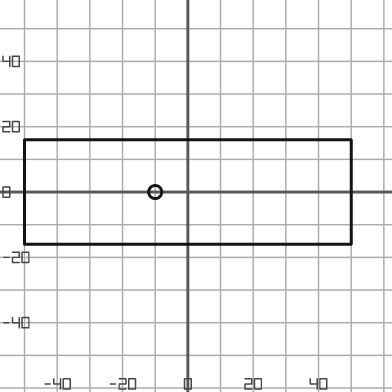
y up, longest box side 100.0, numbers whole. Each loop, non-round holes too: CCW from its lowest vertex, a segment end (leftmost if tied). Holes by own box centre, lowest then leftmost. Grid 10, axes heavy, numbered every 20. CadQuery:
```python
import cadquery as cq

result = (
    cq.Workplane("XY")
    .moveTo(-50.0, -16.0)
    .lineTo(50.0, -16.0)
    .lineTo(50.0, 16.0)
    .lineTo(-50.0, 16.0)
    .close()
    .moveTo(-10.0, 0.0)
    .circle(2.0)
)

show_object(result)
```